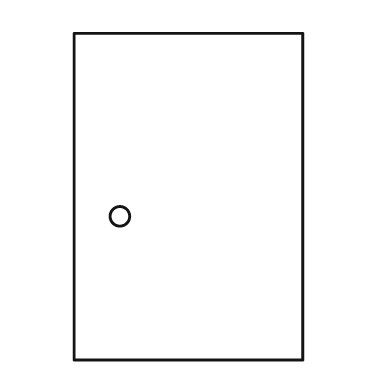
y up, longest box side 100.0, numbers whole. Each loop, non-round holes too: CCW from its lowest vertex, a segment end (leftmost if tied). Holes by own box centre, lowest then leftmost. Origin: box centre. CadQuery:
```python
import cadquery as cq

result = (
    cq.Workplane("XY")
    .moveTo(-35.0, -50.0)
    .lineTo(35.0, -50.0)
    .lineTo(35.0, 50.0)
    .lineTo(-35.0, 50.0)
    .close()
    .moveTo(-21.0, -6.0)
    .circle(3.0)
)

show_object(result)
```